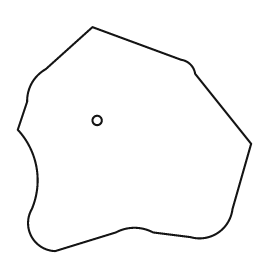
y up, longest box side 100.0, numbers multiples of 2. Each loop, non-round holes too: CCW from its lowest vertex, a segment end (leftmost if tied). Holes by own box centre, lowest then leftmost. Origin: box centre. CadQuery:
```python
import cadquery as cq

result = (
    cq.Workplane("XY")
    .moveTo(-34.0, -48.0)
    .lineTo(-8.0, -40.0)
    .threePointArc((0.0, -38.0), (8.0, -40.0))
    .lineTo(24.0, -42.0)
    .threePointArc((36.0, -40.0), (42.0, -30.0))
    .lineTo(50.0, -2.0)
    .lineTo(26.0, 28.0)
    .threePointArc((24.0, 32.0), (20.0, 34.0))
    .lineTo(-18.0, 48.0)
    .lineTo(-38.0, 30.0)
    .threePointArc((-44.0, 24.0), (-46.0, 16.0))
    .lineTo(-50.0, 4.0)
    .threePointArc((-42.0, -12.0), (-44.0, -30.0))
    .threePointArc((-44.0, -42.0), (-34.0, -48.0))
    .close()
    .moveTo(-16.0, 8.0)
    .circle(2.0)
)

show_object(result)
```